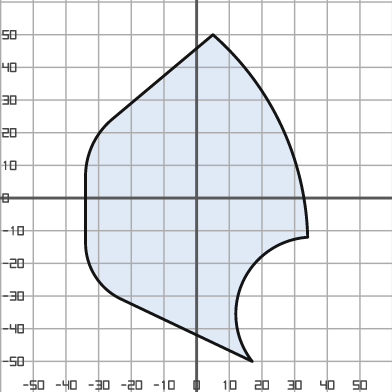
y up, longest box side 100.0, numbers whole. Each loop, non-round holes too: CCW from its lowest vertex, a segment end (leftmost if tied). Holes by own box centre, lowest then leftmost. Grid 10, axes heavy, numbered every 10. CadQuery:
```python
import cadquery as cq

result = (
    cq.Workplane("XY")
    .moveTo(17.0, -50.0)
    .threePointArc((14.0, -26.0), (34.0, -12.0))
    .threePointArc((26.0, 22.0), (5.0, 50.0))
    .lineTo(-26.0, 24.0)
    .threePointArc((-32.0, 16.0), (-34.0, 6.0))
    .lineTo(-34.0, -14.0)
    .threePointArc((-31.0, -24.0), (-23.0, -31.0))
    .close()
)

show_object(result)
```